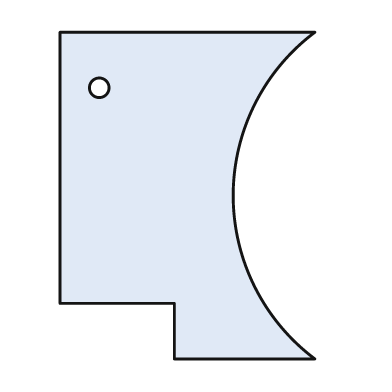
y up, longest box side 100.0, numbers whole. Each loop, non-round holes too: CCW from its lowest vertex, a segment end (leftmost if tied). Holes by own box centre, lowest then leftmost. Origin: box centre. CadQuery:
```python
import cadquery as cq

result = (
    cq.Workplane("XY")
    .moveTo(-4.0, -50.0)
    .lineTo(39.0, -50.0)
    .threePointArc((14.0, 0.0), (39.0, 50.0))
    .lineTo(-39.0, 50.0)
    .lineTo(-39.0, -33.0)
    .lineTo(-4.0, -33.0)
    .close()
    .moveTo(-27.0, 33.0)
    .circle(3.0)
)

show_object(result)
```